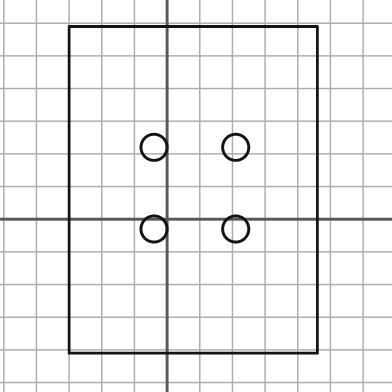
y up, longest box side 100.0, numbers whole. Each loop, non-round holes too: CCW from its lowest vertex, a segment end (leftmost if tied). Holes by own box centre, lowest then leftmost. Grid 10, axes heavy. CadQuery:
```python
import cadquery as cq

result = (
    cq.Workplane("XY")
    .moveTo(-30.0, -41.0)
    .lineTo(46.0, -41.0)
    .lineTo(46.0, 59.0)
    .lineTo(-30.0, 59.0)
    .close()
    .moveTo(-4.0, -3.0)
    .circle(4.0)
    .moveTo(21.0, -3.0)
    .circle(4.0)
    .moveTo(-4.0, 22.0)
    .circle(4.0)
    .moveTo(21.0, 22.0)
    .circle(4.0)
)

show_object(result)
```